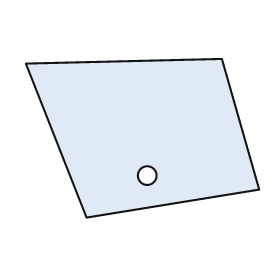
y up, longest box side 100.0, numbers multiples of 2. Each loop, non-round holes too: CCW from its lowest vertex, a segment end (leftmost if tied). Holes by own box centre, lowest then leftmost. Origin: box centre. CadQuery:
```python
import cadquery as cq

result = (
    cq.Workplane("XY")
    .moveTo(-24.0, -34.0)
    .lineTo(50.0, -22.0)
    .lineTo(34.0, 34.0)
    .lineTo(-50.0, 32.0)
    .close()
    .moveTo(2.0, -16.0)
    .circle(4.0)
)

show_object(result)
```